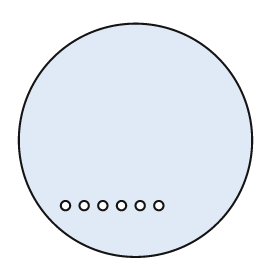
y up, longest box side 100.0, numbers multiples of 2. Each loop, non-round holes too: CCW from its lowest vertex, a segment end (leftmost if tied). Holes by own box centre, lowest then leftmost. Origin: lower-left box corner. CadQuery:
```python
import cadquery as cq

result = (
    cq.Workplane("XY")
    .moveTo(50.0, 50.0)
    .circle(50.0)
    .moveTo(20.0, 22.0)
    .circle(2.0)
    .moveTo(28.0, 22.0)
    .circle(2.0)
    .moveTo(36.0, 22.0)
    .circle(2.0)
    .moveTo(44.0, 22.0)
    .circle(2.0)
    .moveTo(52.0, 22.0)
    .circle(2.0)
    .moveTo(60.0, 22.0)
    .circle(2.0)
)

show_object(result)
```